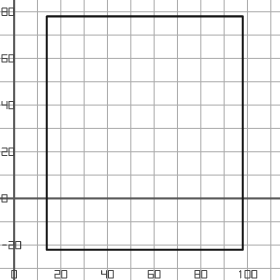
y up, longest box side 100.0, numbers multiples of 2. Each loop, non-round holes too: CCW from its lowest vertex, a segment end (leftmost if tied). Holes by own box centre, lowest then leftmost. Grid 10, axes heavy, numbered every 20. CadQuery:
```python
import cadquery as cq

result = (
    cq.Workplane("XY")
    .moveTo(14.0, -22.0)
    .lineTo(98.0, -22.0)
    .lineTo(98.0, 78.0)
    .lineTo(14.0, 78.0)
    .close()
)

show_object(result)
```